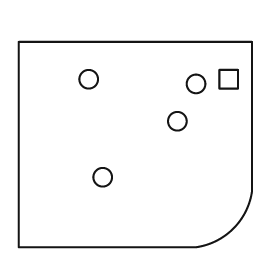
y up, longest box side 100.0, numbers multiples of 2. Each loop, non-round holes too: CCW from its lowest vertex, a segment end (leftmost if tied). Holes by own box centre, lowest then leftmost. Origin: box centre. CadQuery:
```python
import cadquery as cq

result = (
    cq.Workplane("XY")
    .moveTo(-50.0, -44.0)
    .lineTo(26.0, -44.0)
    .threePointArc((42.0, -36.0), (50.0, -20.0))
    .lineTo(50.0, 44.0)
    .lineTo(-50.0, 44.0)
    .close()
    .moveTo(-14.0, -14.0)
    .circle(4.0)
    .moveTo(18.0, 10.0)
    .circle(4.0)
    .moveTo(26.0, 26.0)
    .circle(4.0)
    .moveTo(-20.0, 28.0)
    .circle(4.0)
    .moveTo(36.0, 24.0)
    .lineTo(44.0, 24.0)
    .lineTo(44.0, 32.0)
    .lineTo(36.0, 32.0)
    .close()
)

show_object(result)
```